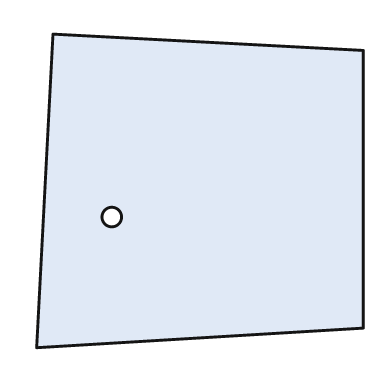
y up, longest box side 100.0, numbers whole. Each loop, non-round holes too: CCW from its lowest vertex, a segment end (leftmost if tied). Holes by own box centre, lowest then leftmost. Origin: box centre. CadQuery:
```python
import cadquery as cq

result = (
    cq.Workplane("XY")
    .moveTo(-50.0, -48.0)
    .lineTo(50.0, -42.0)
    .lineTo(50.0, 43.0)
    .lineTo(-45.0, 48.0)
    .close()
    .moveTo(-27.0, -8.0)
    .circle(3.0)
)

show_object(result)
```